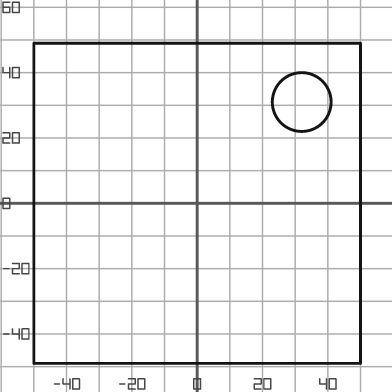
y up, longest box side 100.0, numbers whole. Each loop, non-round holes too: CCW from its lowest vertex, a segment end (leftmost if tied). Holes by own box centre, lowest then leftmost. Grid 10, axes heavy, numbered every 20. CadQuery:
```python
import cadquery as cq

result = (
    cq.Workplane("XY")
    .moveTo(-50.0, -49.0)
    .lineTo(50.0, -49.0)
    .lineTo(50.0, 49.0)
    .lineTo(-50.0, 49.0)
    .close()
    .moveTo(32.0, 31.0)
    .circle(9.0)
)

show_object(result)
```